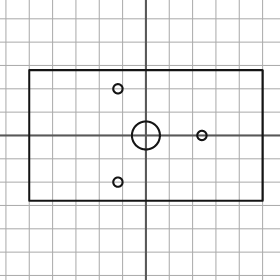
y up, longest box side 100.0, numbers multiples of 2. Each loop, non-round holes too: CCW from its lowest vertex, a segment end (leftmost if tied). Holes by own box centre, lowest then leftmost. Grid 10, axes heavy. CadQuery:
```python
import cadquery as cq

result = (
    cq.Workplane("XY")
    .moveTo(-50.0, -28.0)
    .lineTo(50.0, -28.0)
    .lineTo(50.0, 28.0)
    .lineTo(-50.0, 28.0)
    .close()
    .moveTo(-12.0, -20.0)
    .circle(2.0)
    .moveTo(0.0, 0.0)
    .circle(6.0)
    .moveTo(24.0, 0.0)
    .circle(2.0)
    .moveTo(-12.0, 20.0)
    .circle(2.0)
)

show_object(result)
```